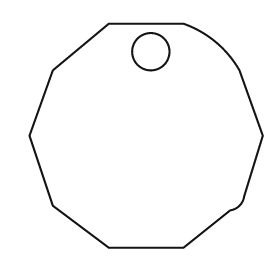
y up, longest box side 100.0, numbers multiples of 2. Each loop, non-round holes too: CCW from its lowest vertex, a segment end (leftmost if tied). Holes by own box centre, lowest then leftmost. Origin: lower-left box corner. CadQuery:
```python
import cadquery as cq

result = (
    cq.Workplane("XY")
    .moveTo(34.0, 0.0)
    .lineTo(66.0, 0.0)
    .lineTo(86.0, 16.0)
    .threePointArc((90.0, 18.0), (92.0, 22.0))
    .lineTo(100.0, 48.0)
    .lineTo(90.0, 76.0)
    .threePointArc((80.0, 88.0), (66.0, 96.0))
    .lineTo(34.0, 96.0)
    .lineTo(10.0, 76.0)
    .lineTo(0.0, 48.0)
    .lineTo(10.0, 18.0)
    .close()
    .moveTo(52.0, 84.0)
    .circle(8.0)
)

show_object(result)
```